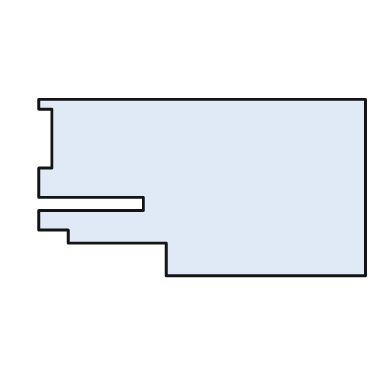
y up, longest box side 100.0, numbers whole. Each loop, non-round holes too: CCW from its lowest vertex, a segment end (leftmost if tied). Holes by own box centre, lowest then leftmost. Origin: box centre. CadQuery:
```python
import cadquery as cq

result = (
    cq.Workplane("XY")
    .moveTo(-11.0, -27.0)
    .lineTo(50.0, -27.0)
    .lineTo(50.0, 27.0)
    .lineTo(-50.0, 27.0)
    .lineTo(-50.0, 24.0)
    .lineTo(-46.0, 24.0)
    .lineTo(-46.0, 6.0)
    .lineTo(-50.0, 6.0)
    .lineTo(-50.0, -3.0)
    .lineTo(-18.0, -3.0)
    .lineTo(-18.0, -7.0)
    .lineTo(-50.0, -7.0)
    .lineTo(-50.0, -13.0)
    .lineTo(-41.0, -13.0)
    .lineTo(-41.0, -17.0)
    .lineTo(-11.0, -17.0)
    .close()
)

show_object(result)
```